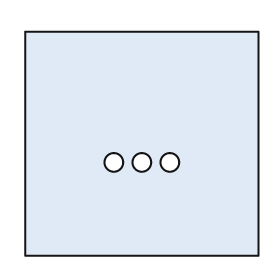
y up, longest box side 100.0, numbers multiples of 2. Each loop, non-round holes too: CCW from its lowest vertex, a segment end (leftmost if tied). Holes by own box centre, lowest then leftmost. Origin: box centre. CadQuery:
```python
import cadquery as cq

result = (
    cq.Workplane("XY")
    .moveTo(-50.0, -48.0)
    .lineTo(50.0, -48.0)
    .lineTo(50.0, 48.0)
    .lineTo(-50.0, 48.0)
    .close()
    .moveTo(-12.0, -8.0)
    .circle(4.0)
    .moveTo(0.0, -8.0)
    .circle(4.0)
    .moveTo(12.0, -8.0)
    .circle(4.0)
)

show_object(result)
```